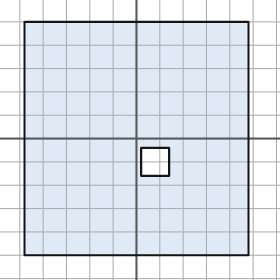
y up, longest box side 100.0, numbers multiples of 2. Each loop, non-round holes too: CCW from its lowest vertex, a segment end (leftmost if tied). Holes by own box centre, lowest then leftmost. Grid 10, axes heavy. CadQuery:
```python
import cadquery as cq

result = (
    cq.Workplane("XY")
    .moveTo(-48.0, -50.0)
    .lineTo(48.0, -50.0)
    .lineTo(48.0, 50.0)
    .lineTo(-48.0, 50.0)
    .close()
    .moveTo(2.0, -16.0)
    .lineTo(14.0, -16.0)
    .lineTo(14.0, -4.0)
    .lineTo(2.0, -4.0)
    .close()
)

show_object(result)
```